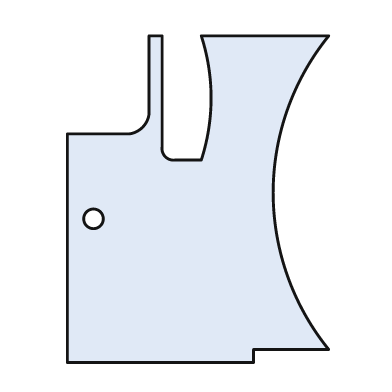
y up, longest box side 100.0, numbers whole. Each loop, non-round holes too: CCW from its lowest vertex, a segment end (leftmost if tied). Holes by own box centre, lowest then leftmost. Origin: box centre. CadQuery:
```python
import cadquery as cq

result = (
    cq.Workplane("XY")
    .moveTo(-40.0, -50.0)
    .lineTo(17.0, -50.0)
    .lineTo(17.0, -46.0)
    .lineTo(40.0, -46.0)
    .threePointArc((23.0, 2.0), (40.0, 50.0))
    .lineTo(1.0, 50.0)
    .threePointArc((4.0, 31.0), (1.0, 12.0))
    .lineTo(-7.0, 12.0)
    .threePointArc((-10.0, 13.0), (-11.0, 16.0))
    .lineTo(-11.0, 50.0)
    .lineTo(-15.0, 50.0)
    .lineTo(-15.0, 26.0)
    .threePointArc((-17.0, 22.0), (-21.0, 20.0))
    .lineTo(-40.0, 20.0)
    .close()
    .moveTo(-32.0, -6.0)
    .circle(3.0)
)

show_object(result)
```